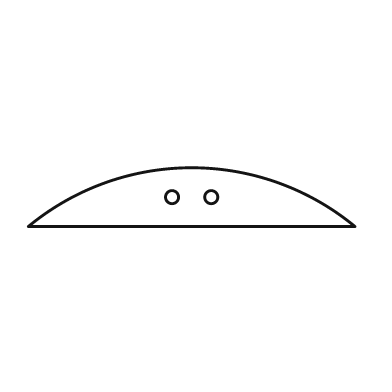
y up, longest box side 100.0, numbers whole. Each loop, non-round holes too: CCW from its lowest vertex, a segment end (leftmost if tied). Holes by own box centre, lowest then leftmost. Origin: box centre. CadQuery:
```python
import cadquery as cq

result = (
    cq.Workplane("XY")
    .moveTo(-50.0, -9.0)
    .lineTo(50.0, -9.0)
    .threePointArc((0.0, 9.0), (-50.0, -9.0))
    .close()
    .moveTo(-6.0, 0.0)
    .circle(2.0)
    .moveTo(6.0, 0.0)
    .circle(2.0)
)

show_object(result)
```